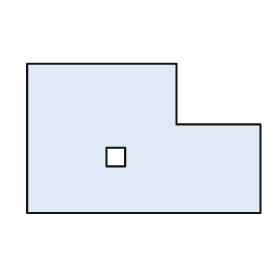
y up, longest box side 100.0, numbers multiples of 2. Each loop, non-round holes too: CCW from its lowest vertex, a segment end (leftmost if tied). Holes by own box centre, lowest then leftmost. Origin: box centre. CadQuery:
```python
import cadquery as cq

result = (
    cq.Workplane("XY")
    .moveTo(-50.0, -32.0)
    .lineTo(50.0, -32.0)
    .lineTo(50.0, 6.0)
    .lineTo(14.0, 6.0)
    .lineTo(14.0, 32.0)
    .lineTo(-50.0, 32.0)
    .close()
    .moveTo(-16.0, -12.0)
    .lineTo(-8.0, -12.0)
    .lineTo(-8.0, -4.0)
    .lineTo(-16.0, -4.0)
    .close()
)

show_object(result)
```